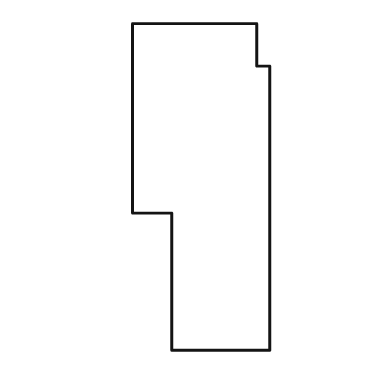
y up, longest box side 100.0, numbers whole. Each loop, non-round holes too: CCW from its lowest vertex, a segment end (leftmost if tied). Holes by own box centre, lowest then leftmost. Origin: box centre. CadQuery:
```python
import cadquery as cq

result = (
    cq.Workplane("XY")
    .moveTo(-9.0, -50.0)
    .lineTo(21.0, -50.0)
    .lineTo(21.0, 37.0)
    .lineTo(17.0, 37.0)
    .lineTo(17.0, 50.0)
    .lineTo(-21.0, 50.0)
    .lineTo(-21.0, -8.0)
    .lineTo(-9.0, -8.0)
    .close()
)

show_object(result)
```